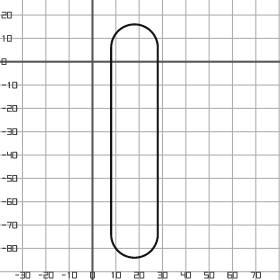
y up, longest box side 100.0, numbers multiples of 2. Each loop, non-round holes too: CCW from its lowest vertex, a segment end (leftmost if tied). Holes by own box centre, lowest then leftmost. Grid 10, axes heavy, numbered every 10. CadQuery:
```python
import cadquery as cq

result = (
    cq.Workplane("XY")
    .moveTo(8.0, -74.0)
    .threePointArc((18.0, -84.0), (28.0, -74.0))
    .lineTo(28.0, 6.0)
    .threePointArc((18.0, 16.0), (8.0, 6.0))
    .close()
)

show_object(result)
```